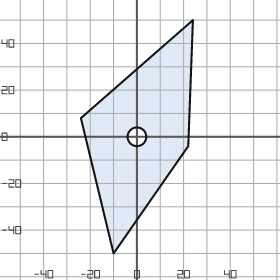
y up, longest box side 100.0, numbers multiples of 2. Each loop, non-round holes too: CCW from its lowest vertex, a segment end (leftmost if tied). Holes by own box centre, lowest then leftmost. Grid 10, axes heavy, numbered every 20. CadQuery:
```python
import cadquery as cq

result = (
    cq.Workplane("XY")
    .moveTo(-10.0, -50.0)
    .lineTo(22.0, -4.0)
    .lineTo(24.0, 50.0)
    .lineTo(-24.0, 8.0)
    .close()
    .moveTo(0.0, 0.0)
    .circle(4.0)
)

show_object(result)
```